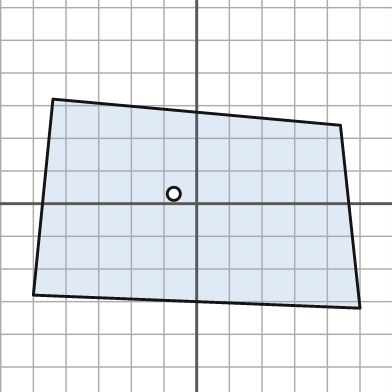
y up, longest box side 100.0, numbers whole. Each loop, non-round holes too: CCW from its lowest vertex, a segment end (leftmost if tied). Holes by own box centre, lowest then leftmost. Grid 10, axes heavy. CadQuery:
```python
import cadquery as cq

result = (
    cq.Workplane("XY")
    .moveTo(50.0, -32.0)
    .lineTo(44.0, 24.0)
    .lineTo(-44.0, 32.0)
    .lineTo(-50.0, -28.0)
    .close()
    .moveTo(-7.0, 3.0)
    .circle(2.0)
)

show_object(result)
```